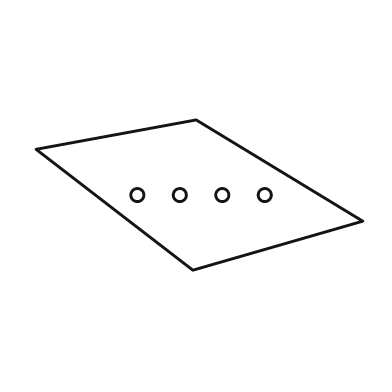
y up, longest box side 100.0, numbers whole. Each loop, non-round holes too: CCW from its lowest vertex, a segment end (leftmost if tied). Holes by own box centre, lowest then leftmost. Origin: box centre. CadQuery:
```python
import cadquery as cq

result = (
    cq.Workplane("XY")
    .moveTo(-2.0, -23.0)
    .lineTo(50.0, -8.0)
    .lineTo(-1.0, 23.0)
    .lineTo(-50.0, 14.0)
    .close()
    .moveTo(-19.0, 0.0)
    .circle(2.0)
    .moveTo(-6.0, 0.0)
    .circle(2.0)
    .moveTo(7.0, 0.0)
    .circle(2.0)
    .moveTo(20.0, 0.0)
    .circle(2.0)
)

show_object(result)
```